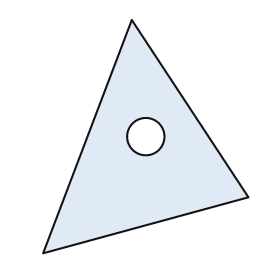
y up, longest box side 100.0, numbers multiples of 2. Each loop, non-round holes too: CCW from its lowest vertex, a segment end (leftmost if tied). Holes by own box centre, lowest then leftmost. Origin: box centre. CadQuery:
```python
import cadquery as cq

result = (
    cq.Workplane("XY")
    .moveTo(-44.0, -50.0)
    .lineTo(44.0, -26.0)
    .lineTo(-6.0, 50.0)
    .close()
    .moveTo(0.0, 0.0)
    .circle(8.0)
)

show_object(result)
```